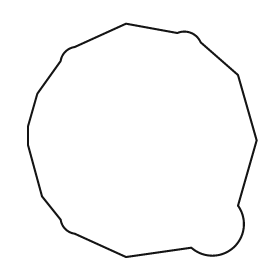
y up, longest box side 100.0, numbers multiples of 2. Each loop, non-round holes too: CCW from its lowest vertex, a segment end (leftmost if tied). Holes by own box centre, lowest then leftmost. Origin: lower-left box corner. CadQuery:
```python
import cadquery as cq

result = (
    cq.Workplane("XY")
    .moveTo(42.0, 0.0)
    .lineTo(70.0, 4.0)
    .threePointArc((88.0, 4.0), (90.0, 22.0))
    .lineTo(98.0, 50.0)
    .lineTo(90.0, 78.0)
    .lineTo(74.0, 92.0)
    .threePointArc((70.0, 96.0), (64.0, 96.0))
    .lineTo(42.0, 100.0)
    .lineTo(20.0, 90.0)
    .threePointArc((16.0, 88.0), (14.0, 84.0))
    .lineTo(4.0, 70.0)
    .lineTo(0.0, 56.0)
    .lineTo(0.0, 48.0)
    .lineTo(6.0, 26.0)
    .lineTo(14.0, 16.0)
    .threePointArc((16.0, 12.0), (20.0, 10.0))
    .close()
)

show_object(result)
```